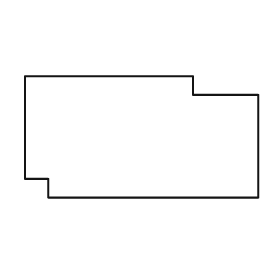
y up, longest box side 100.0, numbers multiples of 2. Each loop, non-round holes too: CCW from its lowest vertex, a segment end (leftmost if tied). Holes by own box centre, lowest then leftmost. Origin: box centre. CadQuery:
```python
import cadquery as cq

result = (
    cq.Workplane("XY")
    .moveTo(-40.0, -26.0)
    .lineTo(50.0, -26.0)
    .lineTo(50.0, 18.0)
    .lineTo(22.0, 18.0)
    .lineTo(22.0, 26.0)
    .lineTo(-50.0, 26.0)
    .lineTo(-50.0, -18.0)
    .lineTo(-40.0, -18.0)
    .close()
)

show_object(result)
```